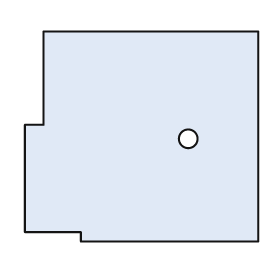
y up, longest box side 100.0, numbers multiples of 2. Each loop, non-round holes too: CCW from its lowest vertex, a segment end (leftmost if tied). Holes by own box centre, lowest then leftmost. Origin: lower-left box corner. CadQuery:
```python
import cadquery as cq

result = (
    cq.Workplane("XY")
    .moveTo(24.0, 0.0)
    .lineTo(100.0, 0.0)
    .lineTo(100.0, 90.0)
    .lineTo(8.0, 90.0)
    .lineTo(8.0, 50.0)
    .lineTo(0.0, 50.0)
    .lineTo(0.0, 4.0)
    .lineTo(24.0, 4.0)
    .close()
    .moveTo(70.0, 44.0)
    .circle(4.0)
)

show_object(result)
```